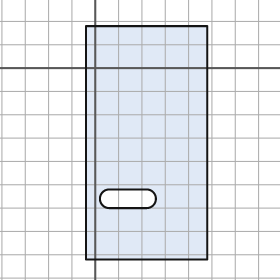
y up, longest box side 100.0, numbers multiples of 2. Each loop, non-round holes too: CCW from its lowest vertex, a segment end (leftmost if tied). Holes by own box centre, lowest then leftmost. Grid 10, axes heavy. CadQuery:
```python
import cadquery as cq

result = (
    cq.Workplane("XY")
    .moveTo(-4.0, -82.0)
    .lineTo(48.0, -82.0)
    .lineTo(48.0, 18.0)
    .lineTo(-4.0, 18.0)
    .close()
    .moveTo(6.0, -60.0)
    .lineTo(22.0, -60.0)
    .threePointArc((26.0, -56.0), (22.0, -52.0))
    .lineTo(6.0, -52.0)
    .threePointArc((2.0, -56.0), (6.0, -60.0))
    .close()
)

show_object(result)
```